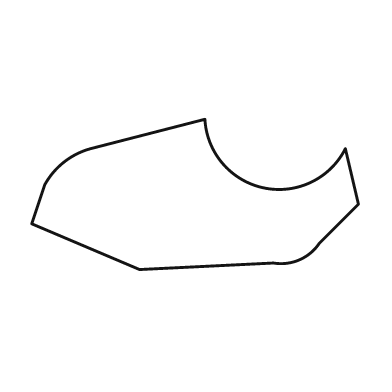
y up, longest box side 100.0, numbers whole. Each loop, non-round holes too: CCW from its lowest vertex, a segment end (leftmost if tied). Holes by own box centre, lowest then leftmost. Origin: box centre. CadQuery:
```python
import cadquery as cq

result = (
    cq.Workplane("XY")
    .moveTo(-17.0, -23.0)
    .lineTo(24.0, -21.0)
    .threePointArc((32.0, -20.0), (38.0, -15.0))
    .lineTo(50.0, -3.0)
    .lineTo(46.0, 14.0)
    .threePointArc((21.0, 2.0), (3.0, 23.0))
    .lineTo(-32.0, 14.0)
    .threePointArc((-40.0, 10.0), (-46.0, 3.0))
    .lineTo(-50.0, -9.0)
    .close()
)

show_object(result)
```